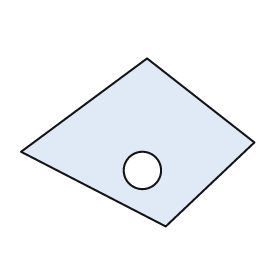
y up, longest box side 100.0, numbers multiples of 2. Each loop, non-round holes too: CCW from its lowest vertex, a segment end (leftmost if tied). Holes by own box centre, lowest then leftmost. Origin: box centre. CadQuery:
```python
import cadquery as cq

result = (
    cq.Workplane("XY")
    .moveTo(12.0, -36.0)
    .lineTo(50.0, 0.0)
    .lineTo(4.0, 36.0)
    .lineTo(-50.0, -4.0)
    .close()
    .moveTo(2.0, -12.0)
    .circle(8.0)
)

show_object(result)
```